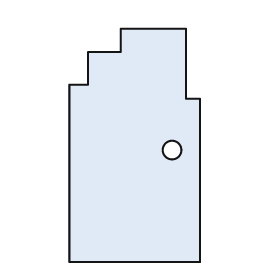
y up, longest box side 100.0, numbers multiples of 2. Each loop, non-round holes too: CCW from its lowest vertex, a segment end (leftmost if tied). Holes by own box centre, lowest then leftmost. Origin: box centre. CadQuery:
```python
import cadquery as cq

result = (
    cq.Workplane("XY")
    .moveTo(-28.0, -50.0)
    .lineTo(28.0, -50.0)
    .lineTo(28.0, 20.0)
    .lineTo(22.0, 20.0)
    .lineTo(22.0, 50.0)
    .lineTo(-6.0, 50.0)
    .lineTo(-6.0, 40.0)
    .lineTo(-20.0, 40.0)
    .lineTo(-20.0, 26.0)
    .lineTo(-28.0, 26.0)
    .close()
    .moveTo(16.0, -2.0)
    .circle(4.0)
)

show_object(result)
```